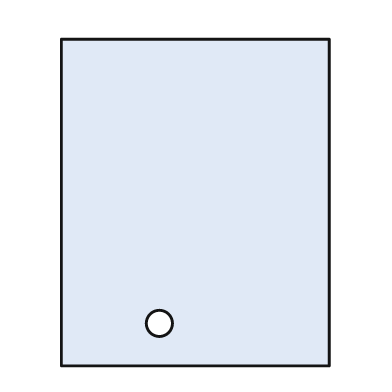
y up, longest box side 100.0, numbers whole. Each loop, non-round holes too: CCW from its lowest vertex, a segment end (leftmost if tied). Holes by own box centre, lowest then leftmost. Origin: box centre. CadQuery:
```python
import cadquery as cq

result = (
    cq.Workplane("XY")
    .moveTo(-41.0, -50.0)
    .lineTo(41.0, -50.0)
    .lineTo(41.0, 50.0)
    .lineTo(-41.0, 50.0)
    .close()
    .moveTo(-11.0, -37.0)
    .circle(4.0)
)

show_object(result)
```